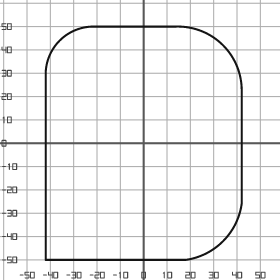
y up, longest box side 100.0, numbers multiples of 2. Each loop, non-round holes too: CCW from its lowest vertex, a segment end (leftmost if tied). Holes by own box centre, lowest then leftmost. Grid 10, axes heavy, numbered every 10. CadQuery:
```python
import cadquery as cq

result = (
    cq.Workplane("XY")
    .moveTo(-42.0, -50.0)
    .lineTo(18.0, -50.0)
    .threePointArc((34.0, -42.0), (42.0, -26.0))
    .lineTo(42.0, 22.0)
    .threePointArc((34.0, 42.0), (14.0, 50.0))
    .lineTo(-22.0, 50.0)
    .threePointArc((-36.0, 44.0), (-42.0, 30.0))
    .close()
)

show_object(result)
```